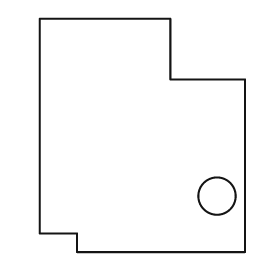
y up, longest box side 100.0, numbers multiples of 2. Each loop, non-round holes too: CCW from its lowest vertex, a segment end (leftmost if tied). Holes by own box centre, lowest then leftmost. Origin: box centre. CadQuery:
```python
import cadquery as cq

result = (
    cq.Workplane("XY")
    .moveTo(-28.0, -50.0)
    .lineTo(44.0, -50.0)
    .lineTo(44.0, 24.0)
    .lineTo(12.0, 24.0)
    .lineTo(12.0, 50.0)
    .lineTo(-44.0, 50.0)
    .lineTo(-44.0, -42.0)
    .lineTo(-28.0, -42.0)
    .close()
    .moveTo(32.0, -26.0)
    .circle(8.0)
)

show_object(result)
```